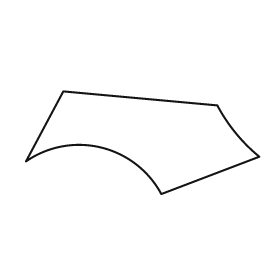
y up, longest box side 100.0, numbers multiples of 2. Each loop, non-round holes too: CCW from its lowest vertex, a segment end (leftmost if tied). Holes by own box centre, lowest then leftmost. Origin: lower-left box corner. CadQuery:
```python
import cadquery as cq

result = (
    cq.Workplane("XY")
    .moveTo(58.0, 0.0)
    .lineTo(100.0, 16.0)
    .threePointArc((90.0, 26.0), (82.0, 38.0))
    .lineTo(16.0, 44.0)
    .lineTo(0.0, 14.0)
    .threePointArc((32.0, 20.0), (58.0, 0.0))
    .close()
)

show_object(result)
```